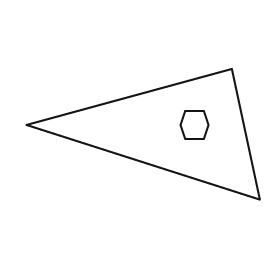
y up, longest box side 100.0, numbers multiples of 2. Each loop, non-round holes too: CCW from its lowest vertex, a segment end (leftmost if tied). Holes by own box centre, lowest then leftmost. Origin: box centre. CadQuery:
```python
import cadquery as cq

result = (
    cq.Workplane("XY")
    .moveTo(50.0, -28.0)
    .lineTo(38.0, 28.0)
    .lineTo(-50.0, 4.0)
    .close()
    .moveTo(18.0, -2.0)
    .lineTo(26.0, -2.0)
    .lineTo(28.0, 4.0)
    .lineTo(26.0, 10.0)
    .lineTo(18.0, 10.0)
    .lineTo(16.0, 4.0)
    .close()
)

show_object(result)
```